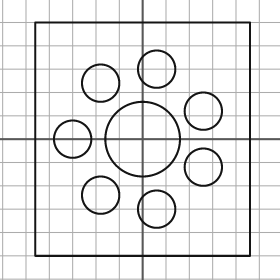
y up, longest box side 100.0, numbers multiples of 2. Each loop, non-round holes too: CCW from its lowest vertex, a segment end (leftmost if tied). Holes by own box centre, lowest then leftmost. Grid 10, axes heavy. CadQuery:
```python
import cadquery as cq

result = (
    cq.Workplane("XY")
    .moveTo(-46.0, -50.0)
    .lineTo(46.0, -50.0)
    .lineTo(46.0, 50.0)
    .lineTo(-46.0, 50.0)
    .close()
    .moveTo(6.0, -30.0)
    .circle(8.0)
    .moveTo(-18.0, -24.0)
    .circle(8.0)
    .moveTo(26.0, -12.0)
    .circle(8.0)
    .moveTo(-30.0, 0.0)
    .circle(8.0)
    .moveTo(0.0, 0.0)
    .circle(16.0)
    .moveTo(26.0, 12.0)
    .circle(8.0)
    .moveTo(-18.0, 24.0)
    .circle(8.0)
    .moveTo(6.0, 30.0)
    .circle(8.0)
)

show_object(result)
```